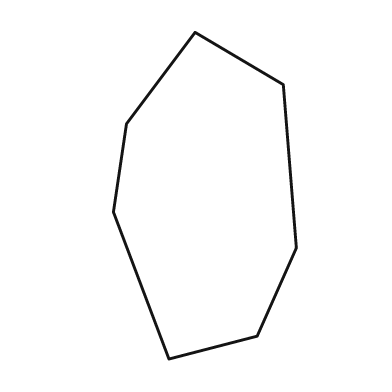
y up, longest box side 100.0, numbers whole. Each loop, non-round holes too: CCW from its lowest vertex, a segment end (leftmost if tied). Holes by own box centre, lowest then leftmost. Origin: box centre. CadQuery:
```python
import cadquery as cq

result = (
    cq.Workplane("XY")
    .moveTo(-11.0, -50.0)
    .lineTo(16.0, -43.0)
    .lineTo(28.0, -16.0)
    .lineTo(24.0, 34.0)
    .lineTo(-3.0, 50.0)
    .lineTo(-24.0, 22.0)
    .lineTo(-28.0, -5.0)
    .close()
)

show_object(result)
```